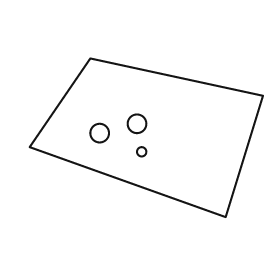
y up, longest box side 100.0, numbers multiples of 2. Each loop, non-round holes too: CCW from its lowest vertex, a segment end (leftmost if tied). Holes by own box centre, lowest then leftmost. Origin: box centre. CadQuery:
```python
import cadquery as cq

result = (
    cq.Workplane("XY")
    .moveTo(34.0, -34.0)
    .lineTo(50.0, 18.0)
    .lineTo(-24.0, 34.0)
    .lineTo(-50.0, -4.0)
    .close()
    .moveTo(-2.0, -6.0)
    .circle(2.0)
    .moveTo(-20.0, 2.0)
    .circle(4.0)
    .moveTo(-4.0, 6.0)
    .circle(4.0)
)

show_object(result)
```